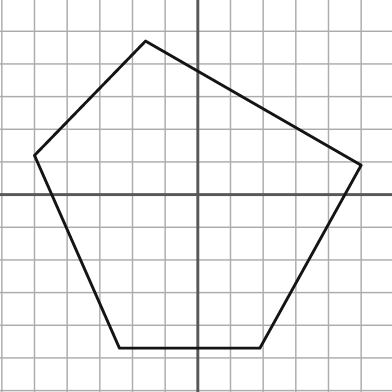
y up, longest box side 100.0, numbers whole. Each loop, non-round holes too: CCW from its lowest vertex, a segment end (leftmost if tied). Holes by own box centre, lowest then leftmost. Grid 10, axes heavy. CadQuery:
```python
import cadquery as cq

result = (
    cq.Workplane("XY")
    .moveTo(-24.0, -47.0)
    .lineTo(19.0, -47.0)
    .lineTo(50.0, 9.0)
    .lineTo(-16.0, 47.0)
    .lineTo(-50.0, 12.0)
    .close()
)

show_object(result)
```